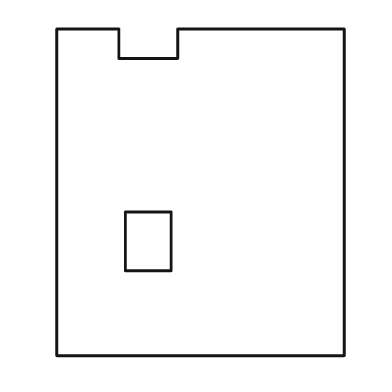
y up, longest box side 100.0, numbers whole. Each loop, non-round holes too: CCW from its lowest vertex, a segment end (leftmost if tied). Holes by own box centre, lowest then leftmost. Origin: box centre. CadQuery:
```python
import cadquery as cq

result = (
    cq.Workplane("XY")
    .moveTo(-44.0, -50.0)
    .lineTo(44.0, -50.0)
    .lineTo(44.0, 50.0)
    .lineTo(-7.0, 50.0)
    .lineTo(-7.0, 41.0)
    .lineTo(-25.0, 41.0)
    .lineTo(-25.0, 50.0)
    .lineTo(-44.0, 50.0)
    .close()
    .moveTo(-23.0, -24.0)
    .lineTo(-9.0, -24.0)
    .lineTo(-9.0, -6.0)
    .lineTo(-23.0, -6.0)
    .close()
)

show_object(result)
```